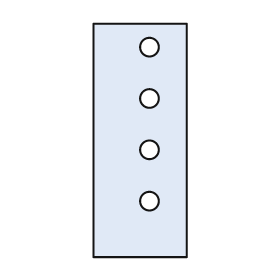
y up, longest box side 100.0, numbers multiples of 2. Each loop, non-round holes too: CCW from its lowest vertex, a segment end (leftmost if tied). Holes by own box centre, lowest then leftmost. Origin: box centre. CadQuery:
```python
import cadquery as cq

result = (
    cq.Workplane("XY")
    .moveTo(-20.0, -50.0)
    .lineTo(20.0, -50.0)
    .lineTo(20.0, 50.0)
    .lineTo(-20.0, 50.0)
    .close()
    .moveTo(4.0, -26.0)
    .circle(4.0)
    .moveTo(4.0, -4.0)
    .circle(4.0)
    .moveTo(4.0, 18.0)
    .circle(4.0)
    .moveTo(4.0, 40.0)
    .circle(4.0)
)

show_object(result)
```